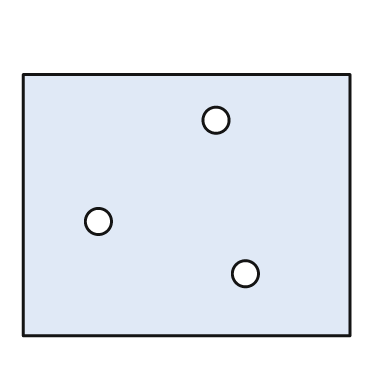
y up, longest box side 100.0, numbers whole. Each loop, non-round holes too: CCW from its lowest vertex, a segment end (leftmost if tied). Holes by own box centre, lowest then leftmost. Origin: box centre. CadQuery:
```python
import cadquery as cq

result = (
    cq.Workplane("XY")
    .moveTo(-50.0, -40.0)
    .lineTo(50.0, -40.0)
    .lineTo(50.0, 40.0)
    .lineTo(-50.0, 40.0)
    .close()
    .moveTo(18.0, -21.0)
    .circle(4.0)
    .moveTo(-27.0, -5.0)
    .circle(4.0)
    .moveTo(9.0, 26.0)
    .circle(4.0)
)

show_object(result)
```